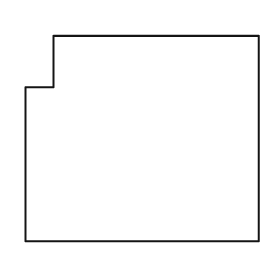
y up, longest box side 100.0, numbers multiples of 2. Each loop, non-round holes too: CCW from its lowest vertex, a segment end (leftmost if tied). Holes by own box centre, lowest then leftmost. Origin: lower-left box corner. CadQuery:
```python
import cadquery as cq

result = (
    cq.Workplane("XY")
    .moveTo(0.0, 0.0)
    .lineTo(100.0, 0.0)
    .lineTo(100.0, 88.0)
    .lineTo(12.0, 88.0)
    .lineTo(12.0, 66.0)
    .lineTo(0.0, 66.0)
    .close()
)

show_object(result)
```